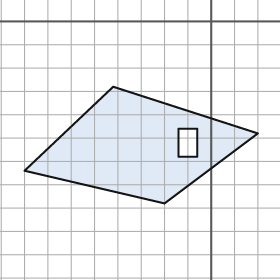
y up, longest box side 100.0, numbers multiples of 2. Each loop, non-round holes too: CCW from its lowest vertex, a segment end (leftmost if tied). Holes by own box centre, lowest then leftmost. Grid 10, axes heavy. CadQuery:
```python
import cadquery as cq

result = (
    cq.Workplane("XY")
    .moveTo(-20.0, -78.0)
    .lineTo(20.0, -48.0)
    .lineTo(-42.0, -28.0)
    .lineTo(-80.0, -64.0)
    .close()
    .moveTo(-14.0, -58.0)
    .lineTo(-6.0, -58.0)
    .lineTo(-6.0, -46.0)
    .lineTo(-14.0, -46.0)
    .close()
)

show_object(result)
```